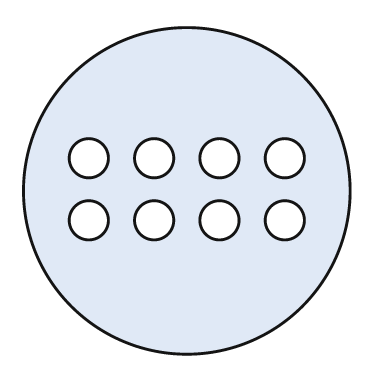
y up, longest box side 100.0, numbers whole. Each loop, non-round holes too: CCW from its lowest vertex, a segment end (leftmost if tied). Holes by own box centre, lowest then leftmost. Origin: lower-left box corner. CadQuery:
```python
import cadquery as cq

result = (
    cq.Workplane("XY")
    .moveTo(50.0, 50.0)
    .circle(50.0)
    .moveTo(20.0, 41.0)
    .circle(6.0)
    .moveTo(40.0, 41.0)
    .circle(6.0)
    .moveTo(60.0, 41.0)
    .circle(6.0)
    .moveTo(80.0, 41.0)
    .circle(6.0)
    .moveTo(20.0, 60.0)
    .circle(6.0)
    .moveTo(40.0, 60.0)
    .circle(6.0)
    .moveTo(60.0, 60.0)
    .circle(6.0)
    .moveTo(80.0, 60.0)
    .circle(6.0)
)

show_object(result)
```